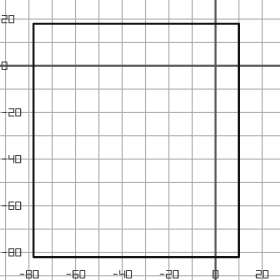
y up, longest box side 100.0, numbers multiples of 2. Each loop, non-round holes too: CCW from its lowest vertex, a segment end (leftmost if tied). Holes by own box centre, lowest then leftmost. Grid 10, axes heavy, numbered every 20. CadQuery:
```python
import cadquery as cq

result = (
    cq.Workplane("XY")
    .moveTo(-78.0, -82.0)
    .lineTo(10.0, -82.0)
    .lineTo(10.0, 18.0)
    .lineTo(-78.0, 18.0)
    .close()
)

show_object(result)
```